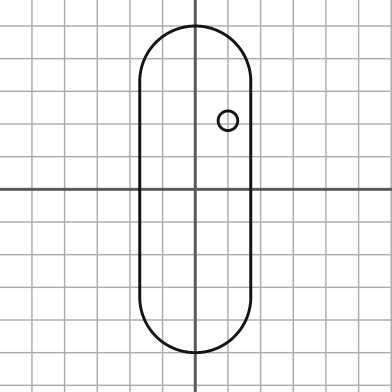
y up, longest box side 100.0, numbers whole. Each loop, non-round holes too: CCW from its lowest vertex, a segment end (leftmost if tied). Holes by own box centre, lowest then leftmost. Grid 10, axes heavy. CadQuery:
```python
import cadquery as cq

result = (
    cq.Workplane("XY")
    .moveTo(-17.0, -33.0)
    .threePointArc((0.0, -50.0), (17.0, -33.0))
    .lineTo(17.0, 33.0)
    .threePointArc((0.0, 50.0), (-17.0, 33.0))
    .close()
    .moveTo(10.0, 21.0)
    .circle(3.0)
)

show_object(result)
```